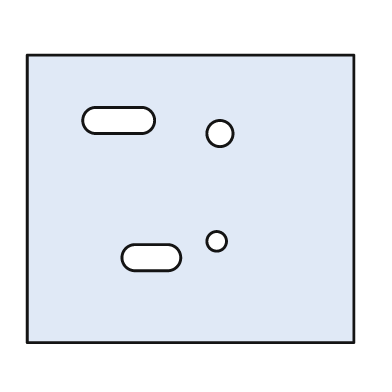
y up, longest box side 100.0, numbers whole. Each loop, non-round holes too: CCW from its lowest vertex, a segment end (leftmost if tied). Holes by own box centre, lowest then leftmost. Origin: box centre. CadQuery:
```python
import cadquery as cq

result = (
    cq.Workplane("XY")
    .moveTo(-50.0, -44.0)
    .lineTo(50.0, -44.0)
    .lineTo(50.0, 44.0)
    .lineTo(-50.0, 44.0)
    .close()
    .moveTo(-17.0, -22.0)
    .lineTo(-7.0, -22.0)
    .threePointArc((-3.0, -18.0), (-7.0, -14.0))
    .lineTo(-17.0, -14.0)
    .threePointArc((-21.0, -18.0), (-17.0, -22.0))
    .close()
    .moveTo(8.0, -13.0)
    .circle(3.0)
    .moveTo(9.0, 20.0)
    .circle(4.0)
    .moveTo(-29.0, 20.0)
    .lineTo(-15.0, 20.0)
    .threePointArc((-11.0, 24.0), (-15.0, 28.0))
    .lineTo(-29.0, 28.0)
    .threePointArc((-33.0, 24.0), (-29.0, 20.0))
    .close()
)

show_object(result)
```